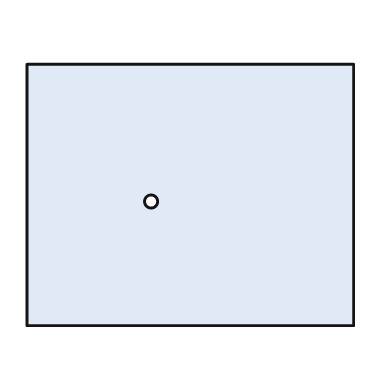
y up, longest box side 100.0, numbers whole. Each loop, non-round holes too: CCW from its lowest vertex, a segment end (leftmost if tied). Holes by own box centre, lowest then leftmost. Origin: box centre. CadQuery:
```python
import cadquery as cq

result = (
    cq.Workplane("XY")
    .moveTo(-50.0, -40.0)
    .lineTo(50.0, -40.0)
    .lineTo(50.0, 40.0)
    .lineTo(-50.0, 40.0)
    .close()
    .moveTo(-12.0, -2.0)
    .circle(2.0)
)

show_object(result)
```